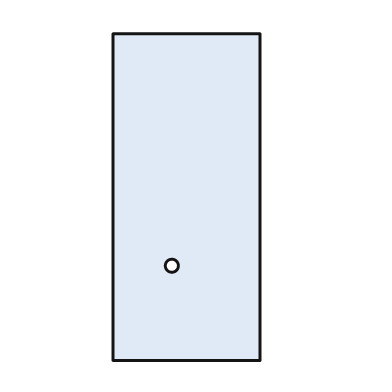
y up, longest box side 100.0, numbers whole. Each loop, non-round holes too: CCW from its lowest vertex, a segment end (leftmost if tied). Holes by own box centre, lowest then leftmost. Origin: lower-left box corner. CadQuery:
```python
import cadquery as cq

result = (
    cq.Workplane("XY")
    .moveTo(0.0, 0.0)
    .lineTo(45.0, 0.0)
    .lineTo(45.0, 100.0)
    .lineTo(0.0, 100.0)
    .close()
    .moveTo(18.0, 29.0)
    .circle(2.0)
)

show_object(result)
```